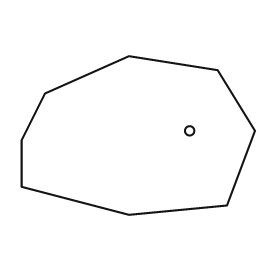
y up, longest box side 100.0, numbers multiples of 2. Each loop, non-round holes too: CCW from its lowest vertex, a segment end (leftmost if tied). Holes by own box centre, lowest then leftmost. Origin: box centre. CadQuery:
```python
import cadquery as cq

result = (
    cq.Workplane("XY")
    .moveTo(-4.0, -34.0)
    .lineTo(38.0, -30.0)
    .lineTo(50.0, 2.0)
    .lineTo(34.0, 28.0)
    .lineTo(-4.0, 34.0)
    .lineTo(-40.0, 18.0)
    .lineTo(-50.0, -2.0)
    .lineTo(-50.0, -22.0)
    .close()
    .moveTo(22.0, 2.0)
    .circle(2.0)
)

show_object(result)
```